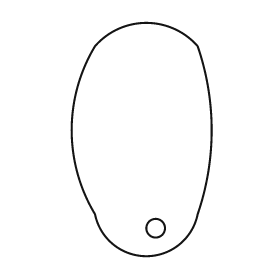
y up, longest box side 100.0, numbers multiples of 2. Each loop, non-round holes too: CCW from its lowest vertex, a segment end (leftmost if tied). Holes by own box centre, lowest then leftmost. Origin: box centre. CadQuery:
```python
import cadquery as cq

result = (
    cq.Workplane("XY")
    .moveTo(-20.0, -32.0)
    .threePointArc((2.0, -50.0), (24.0, -32.0))
    .threePointArc((30.0, 4.0), (24.0, 40.0))
    .threePointArc((2.0, 50.0), (-20.0, 40.0))
    .threePointArc((-30.0, 4.0), (-20.0, -32.0))
    .close()
    .moveTo(6.0, -38.0)
    .circle(4.0)
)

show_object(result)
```